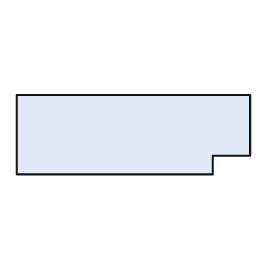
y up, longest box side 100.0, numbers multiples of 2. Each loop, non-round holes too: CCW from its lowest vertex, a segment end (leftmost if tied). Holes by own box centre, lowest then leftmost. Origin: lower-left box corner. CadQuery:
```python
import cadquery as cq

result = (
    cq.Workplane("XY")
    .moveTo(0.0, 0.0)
    .lineTo(84.0, 0.0)
    .lineTo(84.0, 8.0)
    .lineTo(100.0, 8.0)
    .lineTo(100.0, 34.0)
    .lineTo(0.0, 34.0)
    .close()
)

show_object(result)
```